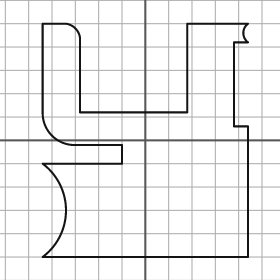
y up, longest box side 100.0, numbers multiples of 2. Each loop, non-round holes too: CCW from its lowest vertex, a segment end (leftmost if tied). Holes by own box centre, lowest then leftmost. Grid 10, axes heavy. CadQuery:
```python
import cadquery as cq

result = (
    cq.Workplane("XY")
    .moveTo(-44.0, -50.0)
    .lineTo(44.0, -50.0)
    .lineTo(44.0, 6.0)
    .lineTo(38.0, 6.0)
    .lineTo(38.0, 42.0)
    .lineTo(44.0, 42.0)
    .threePointArc((42.0, 46.0), (44.0, 50.0))
    .lineTo(18.0, 50.0)
    .lineTo(18.0, 12.0)
    .lineTo(-28.0, 12.0)
    .lineTo(-28.0, 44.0)
    .threePointArc((-30.0, 48.0), (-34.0, 50.0))
    .lineTo(-44.0, 50.0)
    .lineTo(-44.0, 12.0)
    .threePointArc((-40.0, 2.0), (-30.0, -2.0))
    .lineTo(-10.0, -2.0)
    .lineTo(-10.0, -10.0)
    .lineTo(-44.0, -10.0)
    .threePointArc((-34.0, -30.0), (-44.0, -50.0))
    .close()
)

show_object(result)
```